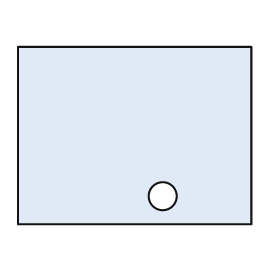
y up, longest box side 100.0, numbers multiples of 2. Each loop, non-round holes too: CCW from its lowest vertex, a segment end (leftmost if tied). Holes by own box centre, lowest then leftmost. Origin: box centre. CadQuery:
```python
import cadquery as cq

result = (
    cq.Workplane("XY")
    .moveTo(-50.0, -38.0)
    .lineTo(50.0, -38.0)
    .lineTo(50.0, 38.0)
    .lineTo(-50.0, 38.0)
    .close()
    .moveTo(12.0, -26.0)
    .circle(6.0)
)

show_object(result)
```